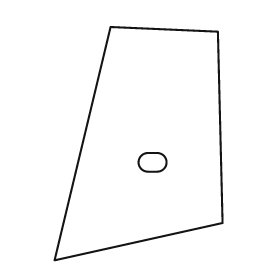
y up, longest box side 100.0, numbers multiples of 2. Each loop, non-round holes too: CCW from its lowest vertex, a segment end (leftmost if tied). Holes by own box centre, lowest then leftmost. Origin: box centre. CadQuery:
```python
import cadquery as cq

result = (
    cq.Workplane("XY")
    .moveTo(-36.0, -50.0)
    .lineTo(36.0, -34.0)
    .lineTo(34.0, 48.0)
    .lineTo(-12.0, 50.0)
    .close()
    .moveTo(4.0, -12.0)
    .lineTo(8.0, -12.0)
    .threePointArc((12.0, -8.0), (8.0, -4.0))
    .lineTo(4.0, -4.0)
    .threePointArc((0.0, -8.0), (4.0, -12.0))
    .close()
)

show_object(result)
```